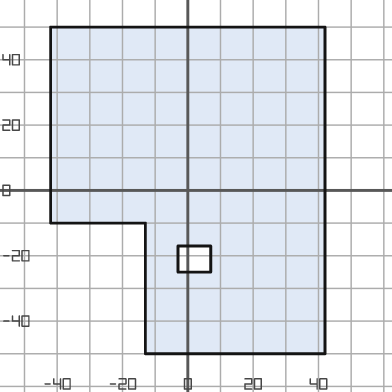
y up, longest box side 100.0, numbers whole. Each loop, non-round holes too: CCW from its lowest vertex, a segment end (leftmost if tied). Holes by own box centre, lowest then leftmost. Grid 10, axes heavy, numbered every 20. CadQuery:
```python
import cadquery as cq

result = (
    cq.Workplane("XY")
    .moveTo(-13.0, -50.0)
    .lineTo(42.0, -50.0)
    .lineTo(42.0, 50.0)
    .lineTo(-42.0, 50.0)
    .lineTo(-42.0, -10.0)
    .lineTo(-13.0, -10.0)
    .close()
    .moveTo(-3.0, -25.0)
    .lineTo(7.0, -25.0)
    .lineTo(7.0, -17.0)
    .lineTo(-3.0, -17.0)
    .close()
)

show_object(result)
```